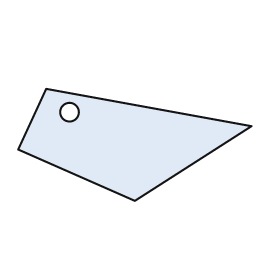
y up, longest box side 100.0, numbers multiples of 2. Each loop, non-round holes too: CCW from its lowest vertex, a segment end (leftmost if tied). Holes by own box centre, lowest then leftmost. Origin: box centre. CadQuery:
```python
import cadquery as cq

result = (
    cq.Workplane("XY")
    .moveTo(0.0, -24.0)
    .lineTo(50.0, 8.0)
    .lineTo(-38.0, 24.0)
    .lineTo(-50.0, -2.0)
    .close()
    .moveTo(-28.0, 14.0)
    .circle(4.0)
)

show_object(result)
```